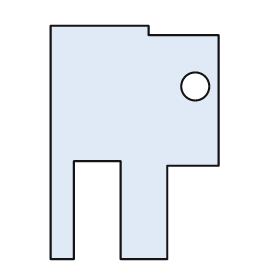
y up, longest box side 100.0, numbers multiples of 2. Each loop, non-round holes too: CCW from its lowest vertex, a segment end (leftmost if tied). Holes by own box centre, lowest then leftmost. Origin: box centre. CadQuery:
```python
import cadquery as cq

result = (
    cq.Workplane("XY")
    .moveTo(-36.0, -50.0)
    .lineTo(-26.0, -50.0)
    .lineTo(-26.0, -8.0)
    .lineTo(-6.0, -8.0)
    .lineTo(-6.0, -50.0)
    .lineTo(14.0, -50.0)
    .lineTo(14.0, -10.0)
    .lineTo(36.0, -10.0)
    .lineTo(36.0, 46.0)
    .lineTo(6.0, 46.0)
    .lineTo(6.0, 50.0)
    .lineTo(-36.0, 50.0)
    .close()
    .moveTo(26.0, 24.0)
    .circle(6.0)
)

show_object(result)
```